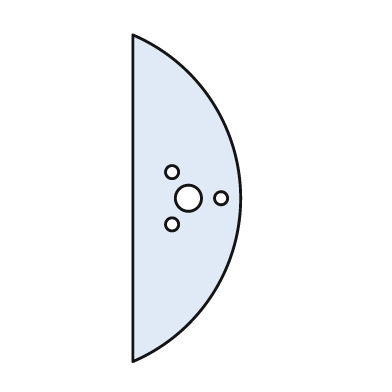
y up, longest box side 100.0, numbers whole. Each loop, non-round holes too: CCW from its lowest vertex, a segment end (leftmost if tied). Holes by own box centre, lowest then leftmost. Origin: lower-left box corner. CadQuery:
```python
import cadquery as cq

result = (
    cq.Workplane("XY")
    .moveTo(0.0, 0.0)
    .threePointArc((33.0, 50.0), (0.0, 100.0))
    .close()
    .moveTo(12.0, 42.0)
    .circle(2.0)
    .moveTo(17.0, 50.0)
    .circle(4.0)
    .moveTo(27.0, 50.0)
    .circle(2.0)
    .moveTo(12.0, 58.0)
    .circle(2.0)
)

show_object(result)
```